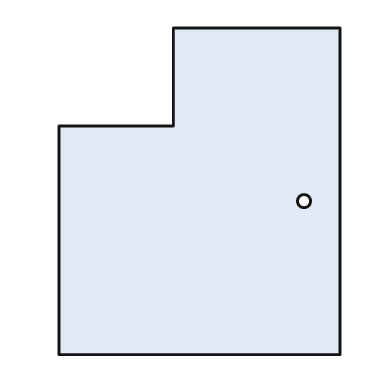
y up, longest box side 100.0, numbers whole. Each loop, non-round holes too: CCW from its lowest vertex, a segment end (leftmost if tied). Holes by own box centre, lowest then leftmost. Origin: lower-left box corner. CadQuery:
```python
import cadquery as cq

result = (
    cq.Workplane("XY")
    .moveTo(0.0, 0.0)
    .lineTo(86.0, 0.0)
    .lineTo(86.0, 100.0)
    .lineTo(35.0, 100.0)
    .lineTo(35.0, 70.0)
    .lineTo(0.0, 70.0)
    .close()
    .moveTo(75.0, 47.0)
    .circle(2.0)
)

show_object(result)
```